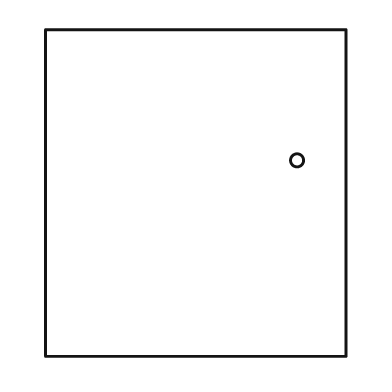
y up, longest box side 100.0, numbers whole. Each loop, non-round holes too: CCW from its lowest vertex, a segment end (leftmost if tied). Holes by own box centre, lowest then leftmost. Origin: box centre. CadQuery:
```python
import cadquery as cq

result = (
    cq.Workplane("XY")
    .moveTo(-46.0, -50.0)
    .lineTo(46.0, -50.0)
    .lineTo(46.0, 50.0)
    .lineTo(-46.0, 50.0)
    .close()
    .moveTo(31.0, 10.0)
    .circle(2.0)
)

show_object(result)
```